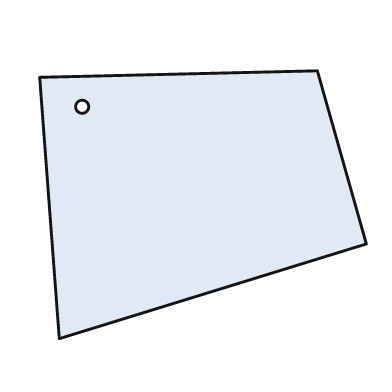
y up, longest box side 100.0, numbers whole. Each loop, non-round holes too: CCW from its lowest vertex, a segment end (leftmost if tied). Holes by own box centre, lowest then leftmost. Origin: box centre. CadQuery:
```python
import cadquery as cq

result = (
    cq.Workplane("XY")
    .moveTo(-44.0, -41.0)
    .lineTo(50.0, -12.0)
    .lineTo(35.0, 41.0)
    .lineTo(-50.0, 39.0)
    .close()
    .moveTo(-37.0, 30.0)
    .circle(2.0)
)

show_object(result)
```